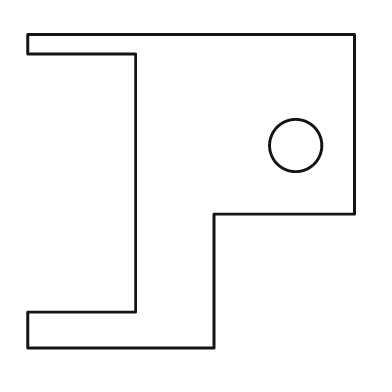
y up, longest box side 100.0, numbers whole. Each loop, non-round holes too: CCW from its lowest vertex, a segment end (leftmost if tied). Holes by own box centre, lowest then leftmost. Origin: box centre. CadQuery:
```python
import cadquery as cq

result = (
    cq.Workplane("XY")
    .moveTo(-50.0, -48.0)
    .lineTo(7.0, -48.0)
    .lineTo(7.0, -7.0)
    .lineTo(50.0, -7.0)
    .lineTo(50.0, 48.0)
    .lineTo(-50.0, 48.0)
    .lineTo(-50.0, 42.0)
    .lineTo(-17.0, 42.0)
    .lineTo(-17.0, -37.0)
    .lineTo(-50.0, -37.0)
    .close()
    .moveTo(32.0, 14.0)
    .circle(8.0)
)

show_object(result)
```